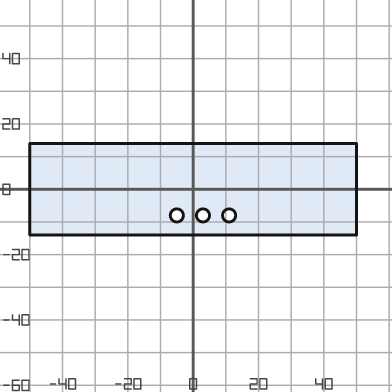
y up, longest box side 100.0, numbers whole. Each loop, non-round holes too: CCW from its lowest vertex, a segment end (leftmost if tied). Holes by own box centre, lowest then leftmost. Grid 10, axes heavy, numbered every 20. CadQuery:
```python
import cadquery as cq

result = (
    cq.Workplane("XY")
    .moveTo(-50.0, -14.0)
    .lineTo(50.0, -14.0)
    .lineTo(50.0, 14.0)
    .lineTo(-50.0, 14.0)
    .close()
    .moveTo(-5.0, -8.0)
    .circle(2.0)
    .moveTo(3.0, -8.0)
    .circle(2.0)
    .moveTo(11.0, -8.0)
    .circle(2.0)
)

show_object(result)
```